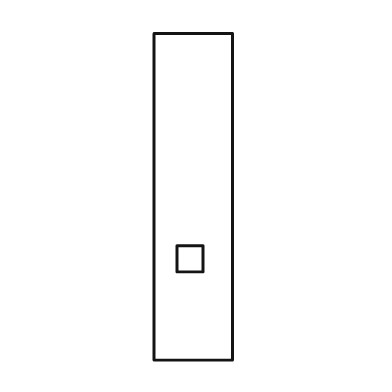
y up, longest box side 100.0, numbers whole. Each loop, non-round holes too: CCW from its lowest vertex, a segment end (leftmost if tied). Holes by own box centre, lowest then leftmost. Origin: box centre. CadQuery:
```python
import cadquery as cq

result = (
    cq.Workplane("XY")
    .moveTo(-12.0, -50.0)
    .lineTo(12.0, -50.0)
    .lineTo(12.0, 50.0)
    .lineTo(-12.0, 50.0)
    .close()
    .moveTo(-5.0, -23.0)
    .lineTo(3.0, -23.0)
    .lineTo(3.0, -15.0)
    .lineTo(-5.0, -15.0)
    .close()
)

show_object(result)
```